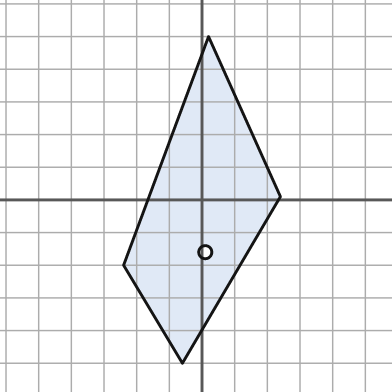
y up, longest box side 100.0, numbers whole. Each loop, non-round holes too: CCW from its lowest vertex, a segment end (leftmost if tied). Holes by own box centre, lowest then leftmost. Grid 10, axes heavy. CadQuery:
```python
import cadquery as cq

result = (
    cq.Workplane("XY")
    .moveTo(-6.0, -50.0)
    .lineTo(24.0, 1.0)
    .lineTo(2.0, 50.0)
    .lineTo(-24.0, -20.0)
    .close()
    .moveTo(1.0, -16.0)
    .circle(2.0)
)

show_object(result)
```